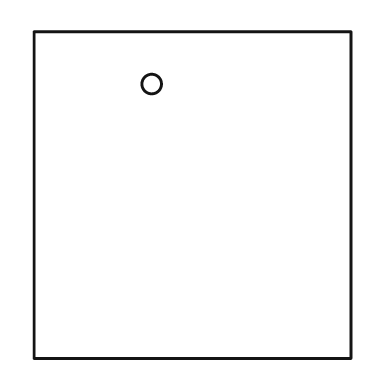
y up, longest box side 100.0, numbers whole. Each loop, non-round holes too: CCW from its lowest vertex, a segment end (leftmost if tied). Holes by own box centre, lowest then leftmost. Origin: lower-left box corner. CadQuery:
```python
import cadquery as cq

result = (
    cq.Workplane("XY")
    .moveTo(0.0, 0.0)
    .lineTo(97.0, 0.0)
    .lineTo(97.0, 100.0)
    .lineTo(0.0, 100.0)
    .close()
    .moveTo(36.0, 84.0)
    .circle(3.0)
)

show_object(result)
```